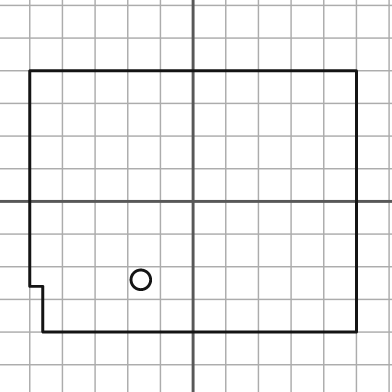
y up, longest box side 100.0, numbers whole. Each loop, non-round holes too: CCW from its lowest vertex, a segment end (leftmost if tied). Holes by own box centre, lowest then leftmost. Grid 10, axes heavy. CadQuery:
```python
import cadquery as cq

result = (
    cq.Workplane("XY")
    .moveTo(-46.0, -40.0)
    .lineTo(50.0, -40.0)
    .lineTo(50.0, 40.0)
    .lineTo(-50.0, 40.0)
    .lineTo(-50.0, -26.0)
    .lineTo(-46.0, -26.0)
    .close()
    .moveTo(-16.0, -24.0)
    .circle(3.0)
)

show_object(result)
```